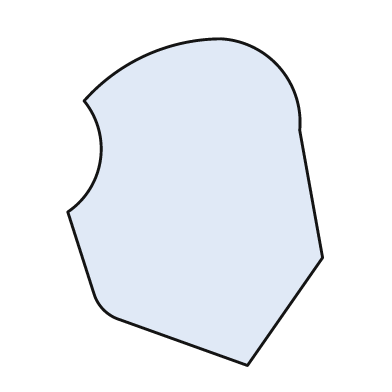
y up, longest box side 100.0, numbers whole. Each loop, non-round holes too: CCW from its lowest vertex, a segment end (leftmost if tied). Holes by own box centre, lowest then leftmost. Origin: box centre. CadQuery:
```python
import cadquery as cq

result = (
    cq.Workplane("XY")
    .moveTo(16.0, -50.0)
    .lineTo(39.0, -17.0)
    .lineTo(32.0, 22.0)
    .threePointArc((26.0, 41.0), (8.0, 50.0))
    .threePointArc((-15.0, 45.0), (-34.0, 31.0))
    .threePointArc((-29.0, 13.0), (-39.0, -3.0))
    .lineTo(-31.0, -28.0)
    .threePointArc((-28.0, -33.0), (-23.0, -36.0))
    .close()
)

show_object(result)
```